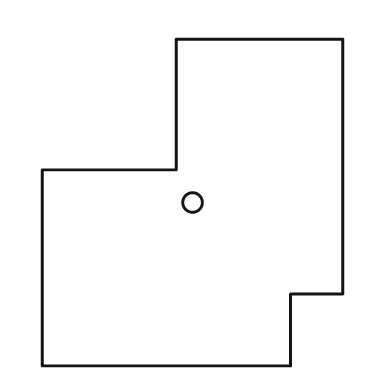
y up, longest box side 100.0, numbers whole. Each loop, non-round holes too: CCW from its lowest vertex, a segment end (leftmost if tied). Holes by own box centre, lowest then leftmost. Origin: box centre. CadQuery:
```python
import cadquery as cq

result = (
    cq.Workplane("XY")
    .moveTo(-46.0, -50.0)
    .lineTo(30.0, -50.0)
    .lineTo(30.0, -28.0)
    .lineTo(46.0, -28.0)
    .lineTo(46.0, 50.0)
    .lineTo(-5.0, 50.0)
    .lineTo(-5.0, 10.0)
    .lineTo(-46.0, 10.0)
    .close()
    .moveTo(0.0, 0.0)
    .circle(3.0)
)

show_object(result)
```